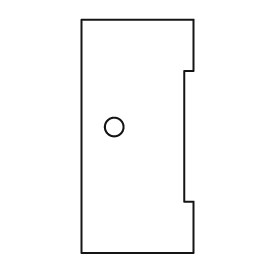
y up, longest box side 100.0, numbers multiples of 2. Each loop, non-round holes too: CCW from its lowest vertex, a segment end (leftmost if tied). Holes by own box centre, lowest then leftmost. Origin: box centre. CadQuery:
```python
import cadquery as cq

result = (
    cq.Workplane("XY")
    .moveTo(-24.0, -50.0)
    .lineTo(24.0, -50.0)
    .lineTo(24.0, -28.0)
    .lineTo(20.0, -28.0)
    .lineTo(20.0, 28.0)
    .lineTo(24.0, 28.0)
    .lineTo(24.0, 50.0)
    .lineTo(-24.0, 50.0)
    .close()
    .moveTo(-10.0, 4.0)
    .circle(4.0)
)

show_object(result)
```